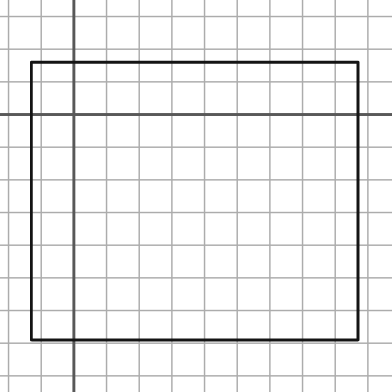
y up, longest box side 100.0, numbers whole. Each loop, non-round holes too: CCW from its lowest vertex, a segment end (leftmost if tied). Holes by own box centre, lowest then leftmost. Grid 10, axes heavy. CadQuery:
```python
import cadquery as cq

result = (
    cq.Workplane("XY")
    .moveTo(-13.0, -69.0)
    .lineTo(87.0, -69.0)
    .lineTo(87.0, 16.0)
    .lineTo(-13.0, 16.0)
    .close()
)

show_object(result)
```